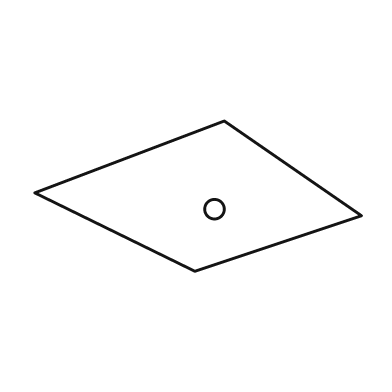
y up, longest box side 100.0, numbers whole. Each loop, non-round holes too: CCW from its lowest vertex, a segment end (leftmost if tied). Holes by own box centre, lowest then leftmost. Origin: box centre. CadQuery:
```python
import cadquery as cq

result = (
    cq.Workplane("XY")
    .moveTo(-1.0, -23.0)
    .lineTo(50.0, -6.0)
    .lineTo(8.0, 23.0)
    .lineTo(-50.0, 1.0)
    .close()
    .moveTo(5.0, -4.0)
    .circle(3.0)
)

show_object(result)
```